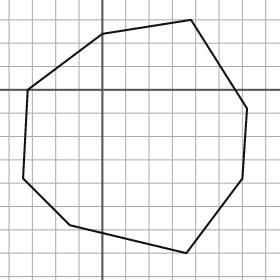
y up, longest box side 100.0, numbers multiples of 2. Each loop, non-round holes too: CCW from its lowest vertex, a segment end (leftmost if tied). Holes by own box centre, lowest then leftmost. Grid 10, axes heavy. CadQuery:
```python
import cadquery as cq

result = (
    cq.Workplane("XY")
    .moveTo(36.0, -70.0)
    .lineTo(60.0, -38.0)
    .lineTo(62.0, -8.0)
    .lineTo(38.0, 30.0)
    .lineTo(0.0, 24.0)
    .lineTo(-32.0, 0.0)
    .lineTo(-34.0, -38.0)
    .lineTo(-14.0, -58.0)
    .close()
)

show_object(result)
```